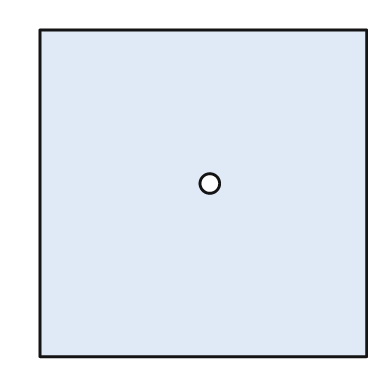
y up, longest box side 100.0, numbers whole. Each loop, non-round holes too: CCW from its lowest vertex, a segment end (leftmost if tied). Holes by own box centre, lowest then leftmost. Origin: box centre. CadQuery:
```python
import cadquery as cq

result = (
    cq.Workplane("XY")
    .moveTo(-50.0, -50.0)
    .lineTo(50.0, -50.0)
    .lineTo(50.0, 50.0)
    .lineTo(-50.0, 50.0)
    .close()
    .moveTo(2.0, 3.0)
    .circle(3.0)
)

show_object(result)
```